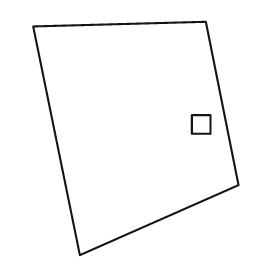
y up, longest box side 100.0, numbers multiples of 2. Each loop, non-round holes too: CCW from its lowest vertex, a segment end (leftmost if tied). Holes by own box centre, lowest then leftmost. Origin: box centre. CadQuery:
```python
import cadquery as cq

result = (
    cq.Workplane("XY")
    .moveTo(-24.0, -50.0)
    .lineTo(44.0, -20.0)
    .lineTo(30.0, 50.0)
    .lineTo(-44.0, 48.0)
    .close()
    .moveTo(24.0, 2.0)
    .lineTo(32.0, 2.0)
    .lineTo(32.0, 10.0)
    .lineTo(24.0, 10.0)
    .close()
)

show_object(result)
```